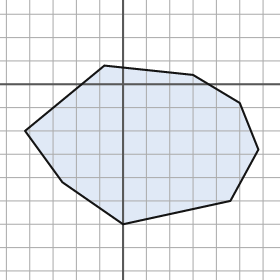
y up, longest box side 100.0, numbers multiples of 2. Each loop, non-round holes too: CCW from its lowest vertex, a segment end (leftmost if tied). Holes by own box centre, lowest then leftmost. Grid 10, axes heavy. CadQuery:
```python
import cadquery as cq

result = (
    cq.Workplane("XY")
    .moveTo(0.0, -60.0)
    .lineTo(46.0, -50.0)
    .lineTo(58.0, -28.0)
    .lineTo(50.0, -8.0)
    .lineTo(30.0, 4.0)
    .lineTo(-8.0, 8.0)
    .lineTo(-42.0, -20.0)
    .lineTo(-26.0, -42.0)
    .close()
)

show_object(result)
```